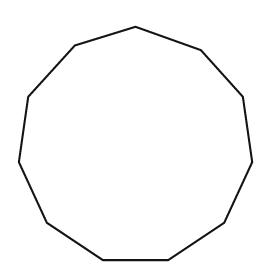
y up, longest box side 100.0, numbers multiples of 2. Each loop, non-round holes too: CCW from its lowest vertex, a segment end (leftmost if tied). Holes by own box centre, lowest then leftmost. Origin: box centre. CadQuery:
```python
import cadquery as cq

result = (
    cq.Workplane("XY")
    .moveTo(-14.0, -50.0)
    .lineTo(14.0, -50.0)
    .lineTo(38.0, -34.0)
    .lineTo(50.0, -8.0)
    .lineTo(46.0, 20.0)
    .lineTo(28.0, 40.0)
    .lineTo(0.0, 50.0)
    .lineTo(-26.0, 42.0)
    .lineTo(-46.0, 20.0)
    .lineTo(-50.0, -8.0)
    .lineTo(-38.0, -34.0)
    .close()
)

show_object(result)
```